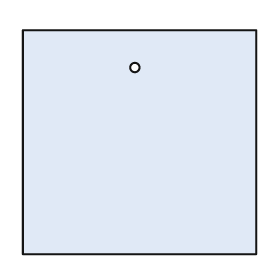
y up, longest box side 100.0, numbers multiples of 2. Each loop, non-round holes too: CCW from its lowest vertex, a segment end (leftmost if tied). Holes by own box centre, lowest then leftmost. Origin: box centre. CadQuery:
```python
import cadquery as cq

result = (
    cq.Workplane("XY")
    .moveTo(-50.0, -48.0)
    .lineTo(50.0, -48.0)
    .lineTo(50.0, 48.0)
    .lineTo(-50.0, 48.0)
    .close()
    .moveTo(-2.0, 32.0)
    .circle(2.0)
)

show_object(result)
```